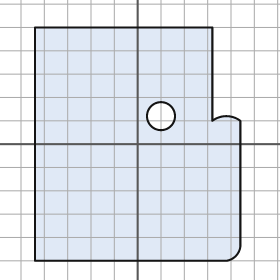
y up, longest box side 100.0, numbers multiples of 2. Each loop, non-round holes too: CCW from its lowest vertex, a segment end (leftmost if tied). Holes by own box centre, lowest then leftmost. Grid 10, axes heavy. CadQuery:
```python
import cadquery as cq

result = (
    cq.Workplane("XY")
    .moveTo(-44.0, -50.0)
    .lineTo(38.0, -50.0)
    .threePointArc((42.0, -48.0), (44.0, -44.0))
    .lineTo(44.0, 10.0)
    .threePointArc((38.0, 12.0), (32.0, 10.0))
    .lineTo(32.0, 50.0)
    .lineTo(-44.0, 50.0)
    .close()
    .moveTo(10.0, 12.0)
    .circle(6.0)
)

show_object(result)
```